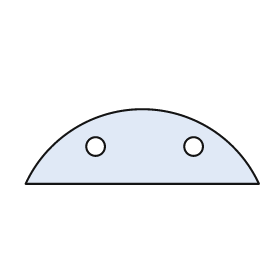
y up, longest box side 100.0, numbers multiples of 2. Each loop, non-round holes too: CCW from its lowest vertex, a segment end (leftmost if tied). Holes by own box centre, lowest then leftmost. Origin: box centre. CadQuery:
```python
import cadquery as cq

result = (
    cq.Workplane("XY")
    .moveTo(-50.0, -16.0)
    .lineTo(50.0, -16.0)
    .threePointArc((0.0, 16.0), (-50.0, -16.0))
    .close()
    .moveTo(-20.0, 0.0)
    .circle(4.0)
    .moveTo(22.0, 0.0)
    .circle(4.0)
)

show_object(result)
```